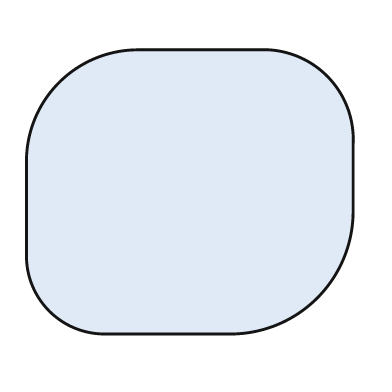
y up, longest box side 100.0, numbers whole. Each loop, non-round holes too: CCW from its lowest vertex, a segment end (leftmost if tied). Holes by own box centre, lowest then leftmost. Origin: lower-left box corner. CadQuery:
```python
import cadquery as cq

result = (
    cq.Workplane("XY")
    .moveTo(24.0, 0.0)
    .lineTo(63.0, 0.0)
    .threePointArc((89.0, 11.0), (100.0, 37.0))
    .lineTo(100.0, 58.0)
    .threePointArc((92.0, 79.0), (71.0, 87.0))
    .lineTo(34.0, 87.0)
    .threePointArc((10.0, 77.0), (0.0, 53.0))
    .lineTo(0.0, 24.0)
    .threePointArc((7.0, 7.0), (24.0, 0.0))
    .close()
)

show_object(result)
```